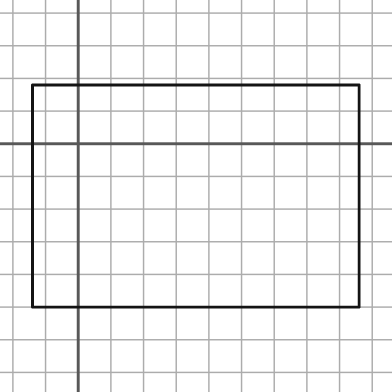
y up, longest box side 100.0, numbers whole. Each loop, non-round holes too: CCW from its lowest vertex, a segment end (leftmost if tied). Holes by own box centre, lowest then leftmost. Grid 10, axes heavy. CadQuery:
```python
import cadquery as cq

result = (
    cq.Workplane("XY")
    .moveTo(-14.0, -50.0)
    .lineTo(86.0, -50.0)
    .lineTo(86.0, 18.0)
    .lineTo(-14.0, 18.0)
    .close()
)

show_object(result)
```